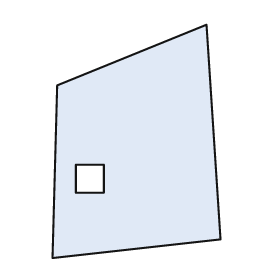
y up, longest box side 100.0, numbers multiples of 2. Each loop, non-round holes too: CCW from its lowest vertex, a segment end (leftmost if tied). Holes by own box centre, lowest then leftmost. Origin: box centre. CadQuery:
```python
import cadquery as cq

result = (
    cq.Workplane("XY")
    .moveTo(-36.0, -50.0)
    .lineTo(36.0, -42.0)
    .lineTo(30.0, 50.0)
    .lineTo(-34.0, 24.0)
    .close()
    .moveTo(-26.0, -22.0)
    .lineTo(-14.0, -22.0)
    .lineTo(-14.0, -10.0)
    .lineTo(-26.0, -10.0)
    .close()
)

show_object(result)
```